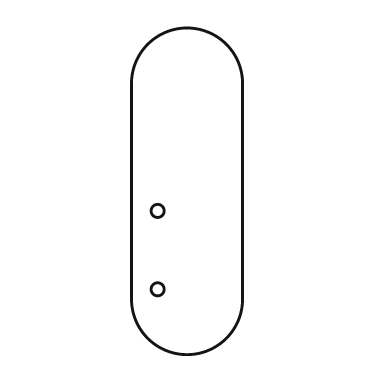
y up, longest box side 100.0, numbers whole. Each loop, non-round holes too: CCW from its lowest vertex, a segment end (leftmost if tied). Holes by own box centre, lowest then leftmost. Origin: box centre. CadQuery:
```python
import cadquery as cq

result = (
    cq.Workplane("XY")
    .moveTo(-17.0, -33.0)
    .threePointArc((0.0, -50.0), (17.0, -33.0))
    .lineTo(17.0, 33.0)
    .threePointArc((0.0, 50.0), (-17.0, 33.0))
    .close()
    .moveTo(-9.0, -30.0)
    .circle(2.0)
    .moveTo(-9.0, -6.0)
    .circle(2.0)
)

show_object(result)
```